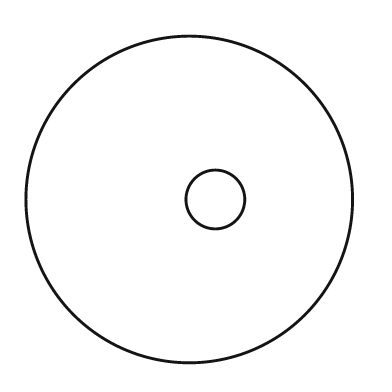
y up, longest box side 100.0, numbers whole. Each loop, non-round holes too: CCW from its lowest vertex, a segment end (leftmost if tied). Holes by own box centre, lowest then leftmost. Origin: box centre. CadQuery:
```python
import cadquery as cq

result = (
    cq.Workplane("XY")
    .moveTo(0.0, 0.0)
    .circle(50.0)
    .moveTo(8.0, 0.0)
    .circle(9.0)
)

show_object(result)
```